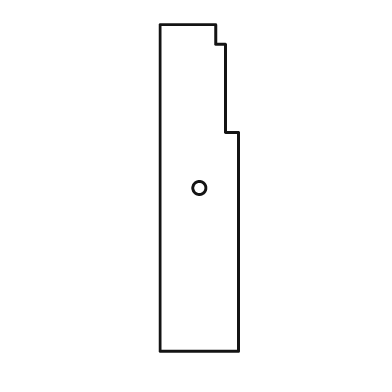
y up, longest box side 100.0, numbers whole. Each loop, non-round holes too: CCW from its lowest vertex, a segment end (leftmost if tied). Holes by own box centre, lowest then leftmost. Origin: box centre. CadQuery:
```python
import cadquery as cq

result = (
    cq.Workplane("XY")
    .moveTo(-12.0, -50.0)
    .lineTo(12.0, -50.0)
    .lineTo(12.0, 17.0)
    .lineTo(8.0, 17.0)
    .lineTo(8.0, 44.0)
    .lineTo(5.0, 44.0)
    .lineTo(5.0, 50.0)
    .lineTo(-12.0, 50.0)
    .close()
    .moveTo(0.0, 0.0)
    .circle(2.0)
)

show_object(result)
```